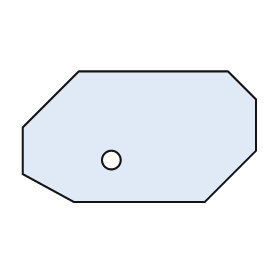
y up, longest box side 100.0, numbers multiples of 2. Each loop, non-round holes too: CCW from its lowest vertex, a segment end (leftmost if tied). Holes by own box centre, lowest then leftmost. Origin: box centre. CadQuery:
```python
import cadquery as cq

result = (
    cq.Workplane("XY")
    .moveTo(-28.0, -28.0)
    .lineTo(28.0, -28.0)
    .lineTo(50.0, -6.0)
    .lineTo(50.0, 16.0)
    .lineTo(38.0, 28.0)
    .lineTo(-26.0, 28.0)
    .lineTo(-50.0, 4.0)
    .lineTo(-50.0, -16.0)
    .close()
    .moveTo(-12.0, -10.0)
    .circle(4.0)
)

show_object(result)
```